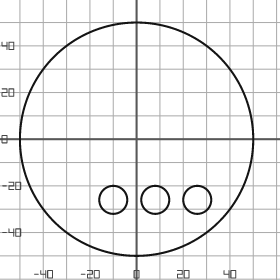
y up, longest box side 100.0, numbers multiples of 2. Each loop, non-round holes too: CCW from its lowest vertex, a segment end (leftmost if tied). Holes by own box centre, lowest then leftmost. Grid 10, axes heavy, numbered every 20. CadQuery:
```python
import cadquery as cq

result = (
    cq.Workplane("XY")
    .moveTo(0.0, 0.0)
    .circle(50.0)
    .moveTo(-10.0, -26.0)
    .circle(6.0)
    .moveTo(8.0, -26.0)
    .circle(6.0)
    .moveTo(26.0, -26.0)
    .circle(6.0)
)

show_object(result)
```